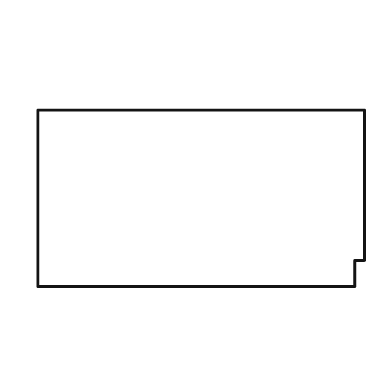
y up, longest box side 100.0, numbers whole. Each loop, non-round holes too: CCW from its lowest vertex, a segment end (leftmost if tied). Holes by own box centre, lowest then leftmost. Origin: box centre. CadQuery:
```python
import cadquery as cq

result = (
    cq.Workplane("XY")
    .moveTo(-50.0, -27.0)
    .lineTo(47.0, -27.0)
    .lineTo(47.0, -19.0)
    .lineTo(50.0, -19.0)
    .lineTo(50.0, 27.0)
    .lineTo(-50.0, 27.0)
    .close()
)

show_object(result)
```